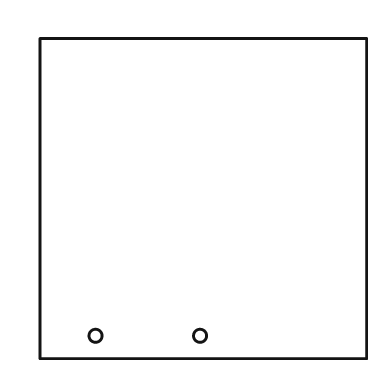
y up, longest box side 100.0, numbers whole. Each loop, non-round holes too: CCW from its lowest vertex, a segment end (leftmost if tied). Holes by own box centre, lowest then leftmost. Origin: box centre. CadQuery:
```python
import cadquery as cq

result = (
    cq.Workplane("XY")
    .moveTo(-50.0, -49.0)
    .lineTo(50.0, -49.0)
    .lineTo(50.0, 49.0)
    .lineTo(-50.0, 49.0)
    .close()
    .moveTo(-33.0, -42.0)
    .circle(2.0)
    .moveTo(-1.0, -42.0)
    .circle(2.0)
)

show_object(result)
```